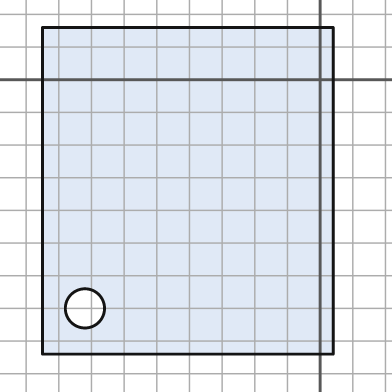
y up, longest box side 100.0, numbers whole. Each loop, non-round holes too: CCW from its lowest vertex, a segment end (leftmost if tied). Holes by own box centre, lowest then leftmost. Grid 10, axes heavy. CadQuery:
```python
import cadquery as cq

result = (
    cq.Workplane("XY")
    .moveTo(-85.0, -84.0)
    .lineTo(4.0, -84.0)
    .lineTo(4.0, 16.0)
    .lineTo(-85.0, 16.0)
    .close()
    .moveTo(-72.0, -70.0)
    .circle(6.0)
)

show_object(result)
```